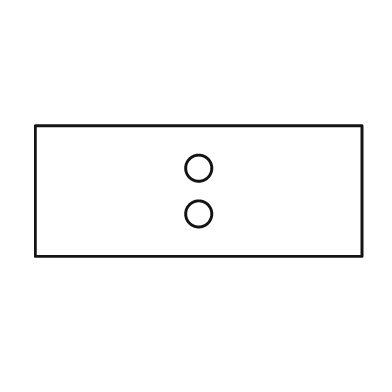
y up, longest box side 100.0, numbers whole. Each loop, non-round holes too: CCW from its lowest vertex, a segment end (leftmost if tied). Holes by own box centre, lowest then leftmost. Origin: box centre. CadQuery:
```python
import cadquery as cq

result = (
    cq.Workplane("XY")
    .moveTo(-50.0, -20.0)
    .lineTo(50.0, -20.0)
    .lineTo(50.0, 20.0)
    .lineTo(-50.0, 20.0)
    .close()
    .moveTo(0.0, -7.0)
    .circle(4.0)
    .moveTo(0.0, 7.0)
    .circle(4.0)
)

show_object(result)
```